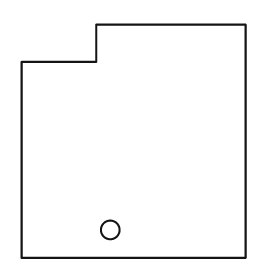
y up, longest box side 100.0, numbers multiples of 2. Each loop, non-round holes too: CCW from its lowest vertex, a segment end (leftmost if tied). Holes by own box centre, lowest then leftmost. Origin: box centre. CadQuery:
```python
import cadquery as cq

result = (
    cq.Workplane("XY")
    .moveTo(-48.0, -50.0)
    .lineTo(48.0, -50.0)
    .lineTo(48.0, 50.0)
    .lineTo(-16.0, 50.0)
    .lineTo(-16.0, 34.0)
    .lineTo(-48.0, 34.0)
    .close()
    .moveTo(-10.0, -38.0)
    .circle(4.0)
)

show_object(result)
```